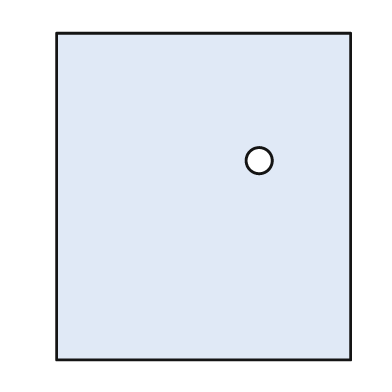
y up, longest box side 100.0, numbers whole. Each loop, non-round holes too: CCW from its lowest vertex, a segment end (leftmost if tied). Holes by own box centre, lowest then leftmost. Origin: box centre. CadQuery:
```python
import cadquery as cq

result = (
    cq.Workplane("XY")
    .moveTo(-45.0, -50.0)
    .lineTo(45.0, -50.0)
    .lineTo(45.0, 50.0)
    .lineTo(-45.0, 50.0)
    .close()
    .moveTo(17.0, 11.0)
    .circle(4.0)
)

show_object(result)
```